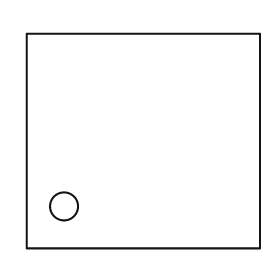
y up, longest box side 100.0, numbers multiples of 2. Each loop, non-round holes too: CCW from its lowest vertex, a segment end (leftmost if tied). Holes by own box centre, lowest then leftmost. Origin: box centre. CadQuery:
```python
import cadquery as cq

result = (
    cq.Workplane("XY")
    .moveTo(-50.0, -46.0)
    .lineTo(50.0, -46.0)
    .lineTo(50.0, 46.0)
    .lineTo(-50.0, 46.0)
    .close()
    .moveTo(-34.0, -28.0)
    .circle(6.0)
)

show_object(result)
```